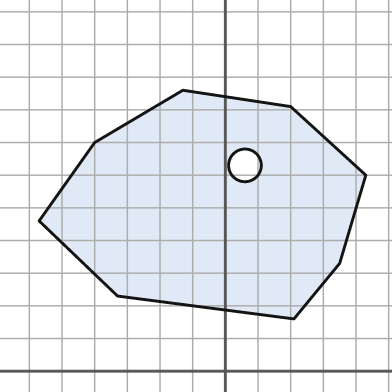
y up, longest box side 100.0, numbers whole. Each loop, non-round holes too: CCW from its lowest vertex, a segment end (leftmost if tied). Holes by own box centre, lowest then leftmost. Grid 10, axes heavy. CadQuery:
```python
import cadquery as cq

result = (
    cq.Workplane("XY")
    .moveTo(21.0, 16.0)
    .lineTo(35.0, 33.0)
    .lineTo(43.0, 60.0)
    .lineTo(20.0, 81.0)
    .lineTo(-13.0, 86.0)
    .lineTo(-40.0, 70.0)
    .lineTo(-57.0, 46.0)
    .lineTo(-33.0, 23.0)
    .close()
    .moveTo(6.0, 63.0)
    .circle(5.0)
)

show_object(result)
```